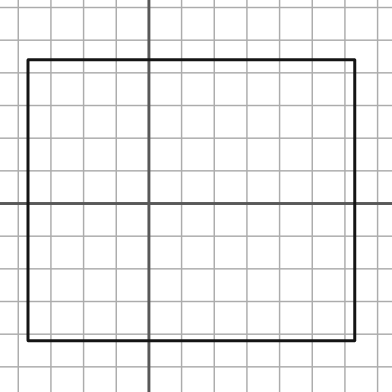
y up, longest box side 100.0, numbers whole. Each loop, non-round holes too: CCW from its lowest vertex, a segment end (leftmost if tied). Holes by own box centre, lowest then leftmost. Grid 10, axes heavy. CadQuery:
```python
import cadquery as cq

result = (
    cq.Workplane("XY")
    .moveTo(-37.0, -42.0)
    .lineTo(63.0, -42.0)
    .lineTo(63.0, 44.0)
    .lineTo(-37.0, 44.0)
    .close()
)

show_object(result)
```